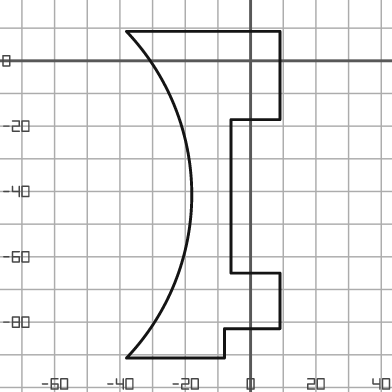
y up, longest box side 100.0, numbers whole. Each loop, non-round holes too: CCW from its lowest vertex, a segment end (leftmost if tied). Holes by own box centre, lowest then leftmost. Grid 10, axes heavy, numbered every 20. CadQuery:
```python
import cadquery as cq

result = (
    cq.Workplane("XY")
    .moveTo(-38.0, -91.0)
    .lineTo(-8.0, -91.0)
    .lineTo(-8.0, -82.0)
    .lineTo(9.0, -82.0)
    .lineTo(9.0, -65.0)
    .lineTo(-6.0, -65.0)
    .lineTo(-6.0, -18.0)
    .lineTo(9.0, -18.0)
    .lineTo(9.0, 9.0)
    .lineTo(-38.0, 9.0)
    .threePointArc((-18.0, -41.0), (-38.0, -91.0))
    .close()
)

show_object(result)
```